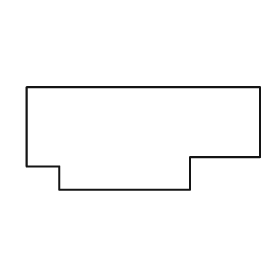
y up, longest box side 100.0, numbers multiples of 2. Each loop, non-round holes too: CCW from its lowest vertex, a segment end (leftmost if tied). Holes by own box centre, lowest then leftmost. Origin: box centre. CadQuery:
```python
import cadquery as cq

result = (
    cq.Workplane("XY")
    .moveTo(-36.0, -22.0)
    .lineTo(20.0, -22.0)
    .lineTo(20.0, -8.0)
    .lineTo(50.0, -8.0)
    .lineTo(50.0, 22.0)
    .lineTo(-50.0, 22.0)
    .lineTo(-50.0, -12.0)
    .lineTo(-36.0, -12.0)
    .close()
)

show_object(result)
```